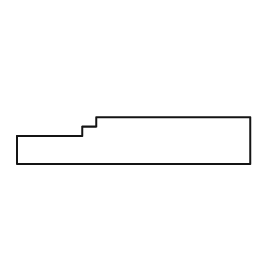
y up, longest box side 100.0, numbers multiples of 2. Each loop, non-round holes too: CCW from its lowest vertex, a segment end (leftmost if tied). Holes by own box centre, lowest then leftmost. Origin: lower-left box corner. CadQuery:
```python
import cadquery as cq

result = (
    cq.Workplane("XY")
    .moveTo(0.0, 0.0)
    .lineTo(100.0, 0.0)
    .lineTo(100.0, 20.0)
    .lineTo(34.0, 20.0)
    .lineTo(34.0, 16.0)
    .lineTo(28.0, 16.0)
    .lineTo(28.0, 12.0)
    .lineTo(0.0, 12.0)
    .close()
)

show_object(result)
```